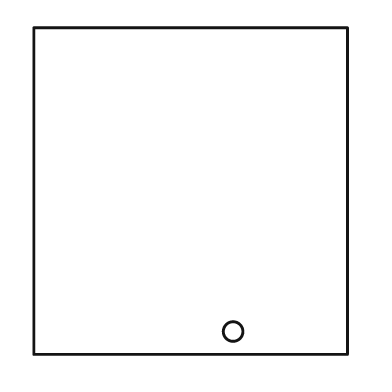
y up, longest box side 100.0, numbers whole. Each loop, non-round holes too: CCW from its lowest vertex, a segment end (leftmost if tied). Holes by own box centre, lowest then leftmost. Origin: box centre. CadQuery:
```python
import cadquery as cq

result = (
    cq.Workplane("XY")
    .moveTo(-48.0, -50.0)
    .lineTo(48.0, -50.0)
    .lineTo(48.0, 50.0)
    .lineTo(-48.0, 50.0)
    .close()
    .moveTo(13.0, -43.0)
    .circle(3.0)
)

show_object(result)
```